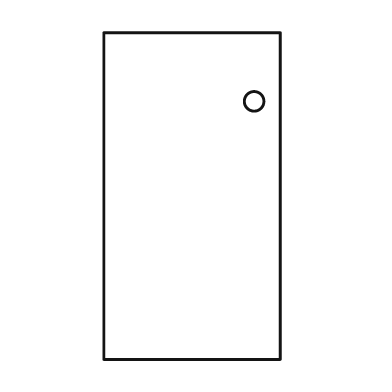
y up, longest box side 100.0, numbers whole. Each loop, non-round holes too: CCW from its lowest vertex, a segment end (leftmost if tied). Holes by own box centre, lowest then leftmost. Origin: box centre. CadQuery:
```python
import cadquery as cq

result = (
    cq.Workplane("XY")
    .moveTo(-27.0, -50.0)
    .lineTo(27.0, -50.0)
    .lineTo(27.0, 50.0)
    .lineTo(-27.0, 50.0)
    .close()
    .moveTo(19.0, 29.0)
    .circle(3.0)
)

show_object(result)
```